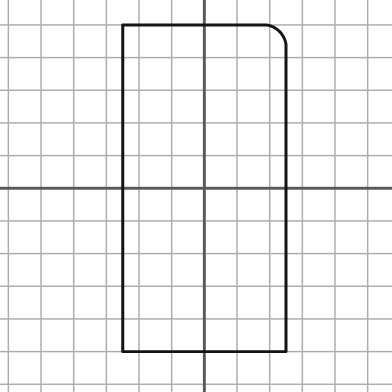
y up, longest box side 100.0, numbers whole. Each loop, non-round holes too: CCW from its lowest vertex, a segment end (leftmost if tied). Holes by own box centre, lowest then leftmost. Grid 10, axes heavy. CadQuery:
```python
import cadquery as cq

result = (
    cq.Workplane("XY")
    .moveTo(-25.0, -50.0)
    .lineTo(25.0, -50.0)
    .lineTo(25.0, 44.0)
    .threePointArc((23.0, 48.0), (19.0, 50.0))
    .lineTo(-25.0, 50.0)
    .close()
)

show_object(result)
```